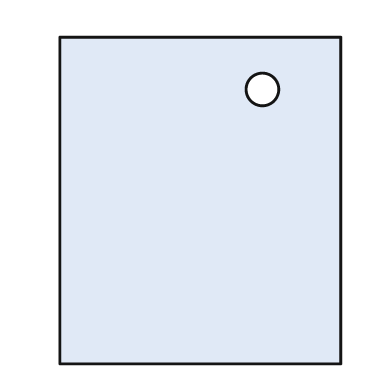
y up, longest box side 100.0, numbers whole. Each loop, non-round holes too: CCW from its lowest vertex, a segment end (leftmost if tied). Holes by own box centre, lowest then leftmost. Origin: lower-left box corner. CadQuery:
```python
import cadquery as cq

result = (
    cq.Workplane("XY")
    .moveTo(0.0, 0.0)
    .lineTo(86.0, 0.0)
    .lineTo(86.0, 100.0)
    .lineTo(0.0, 100.0)
    .close()
    .moveTo(62.0, 84.0)
    .circle(5.0)
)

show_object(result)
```